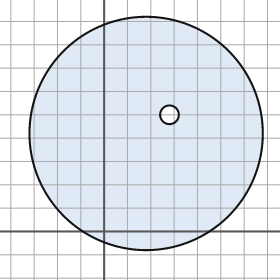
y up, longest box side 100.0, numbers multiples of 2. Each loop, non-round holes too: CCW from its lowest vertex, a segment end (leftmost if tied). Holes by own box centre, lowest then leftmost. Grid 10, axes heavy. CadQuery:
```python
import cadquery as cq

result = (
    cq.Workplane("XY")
    .moveTo(18.0, 42.0)
    .circle(50.0)
    .moveTo(28.0, 50.0)
    .circle(4.0)
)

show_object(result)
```